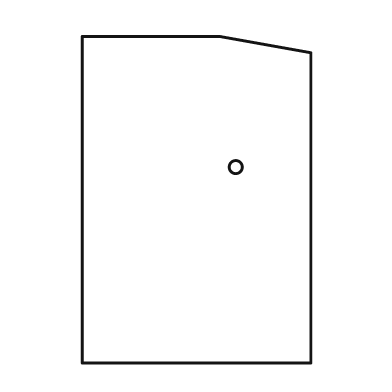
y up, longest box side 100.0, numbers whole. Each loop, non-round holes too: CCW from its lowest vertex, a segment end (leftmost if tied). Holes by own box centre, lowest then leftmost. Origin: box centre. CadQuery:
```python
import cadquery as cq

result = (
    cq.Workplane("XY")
    .moveTo(-35.0, -50.0)
    .lineTo(35.0, -50.0)
    .lineTo(35.0, 45.0)
    .lineTo(7.0, 50.0)
    .lineTo(-35.0, 50.0)
    .close()
    .moveTo(12.0, 10.0)
    .circle(2.0)
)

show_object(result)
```